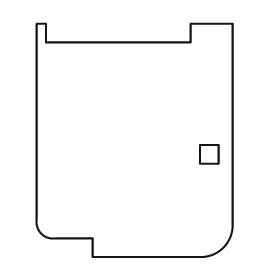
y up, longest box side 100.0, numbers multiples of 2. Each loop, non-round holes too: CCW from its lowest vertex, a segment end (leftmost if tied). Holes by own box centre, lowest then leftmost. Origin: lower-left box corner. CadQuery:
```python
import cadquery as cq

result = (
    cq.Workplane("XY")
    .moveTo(24.0, 0.0)
    .lineTo(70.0, 0.0)
    .threePointArc((80.0, 4.0), (84.0, 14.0))
    .lineTo(84.0, 100.0)
    .lineTo(66.0, 100.0)
    .lineTo(66.0, 92.0)
    .lineTo(4.0, 92.0)
    .lineTo(4.0, 100.0)
    .lineTo(0.0, 100.0)
    .lineTo(0.0, 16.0)
    .threePointArc((2.0, 10.0), (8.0, 8.0))
    .lineTo(24.0, 8.0)
    .close()
    .moveTo(70.0, 40.0)
    .lineTo(78.0, 40.0)
    .lineTo(78.0, 48.0)
    .lineTo(70.0, 48.0)
    .close()
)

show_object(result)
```